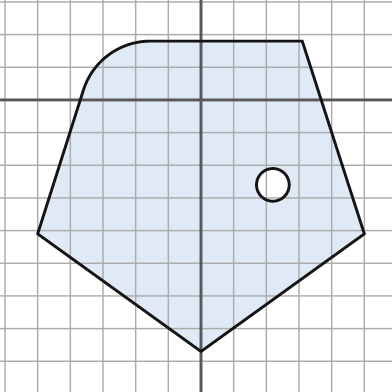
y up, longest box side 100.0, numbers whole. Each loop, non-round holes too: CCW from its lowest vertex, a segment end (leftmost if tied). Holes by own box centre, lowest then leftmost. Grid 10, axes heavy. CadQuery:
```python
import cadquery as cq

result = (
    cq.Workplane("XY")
    .moveTo(0.0, -77.0)
    .lineTo(50.0, -41.0)
    .lineTo(31.0, 18.0)
    .lineTo(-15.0, 18.0)
    .threePointArc((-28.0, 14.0), (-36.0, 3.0))
    .lineTo(-50.0, -41.0)
    .close()
    .moveTo(22.0, -26.0)
    .circle(5.0)
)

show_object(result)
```